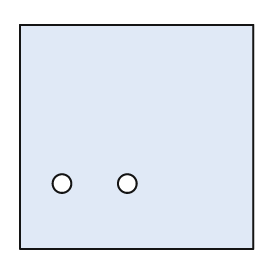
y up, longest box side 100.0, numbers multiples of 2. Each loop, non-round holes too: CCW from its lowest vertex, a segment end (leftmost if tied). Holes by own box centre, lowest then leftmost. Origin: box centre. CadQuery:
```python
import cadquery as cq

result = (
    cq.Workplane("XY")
    .moveTo(-50.0, -48.0)
    .lineTo(50.0, -48.0)
    .lineTo(50.0, 48.0)
    .lineTo(-50.0, 48.0)
    .close()
    .moveTo(-32.0, -20.0)
    .circle(4.0)
    .moveTo(-4.0, -20.0)
    .circle(4.0)
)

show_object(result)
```